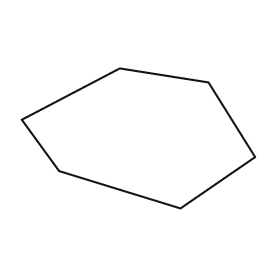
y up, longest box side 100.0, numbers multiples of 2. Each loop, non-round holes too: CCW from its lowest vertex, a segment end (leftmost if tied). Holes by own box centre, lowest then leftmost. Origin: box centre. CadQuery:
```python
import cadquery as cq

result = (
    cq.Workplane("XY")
    .moveTo(18.0, -30.0)
    .lineTo(50.0, -8.0)
    .lineTo(30.0, 24.0)
    .lineTo(-8.0, 30.0)
    .lineTo(-50.0, 8.0)
    .lineTo(-34.0, -14.0)
    .close()
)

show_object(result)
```